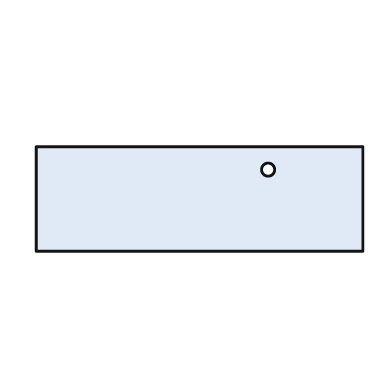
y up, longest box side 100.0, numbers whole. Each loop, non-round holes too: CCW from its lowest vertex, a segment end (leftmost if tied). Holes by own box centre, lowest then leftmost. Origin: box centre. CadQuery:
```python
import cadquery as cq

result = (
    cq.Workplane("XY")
    .moveTo(-50.0, -16.0)
    .lineTo(50.0, -16.0)
    .lineTo(50.0, 16.0)
    .lineTo(-50.0, 16.0)
    .close()
    .moveTo(21.0, 9.0)
    .circle(2.0)
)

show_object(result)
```